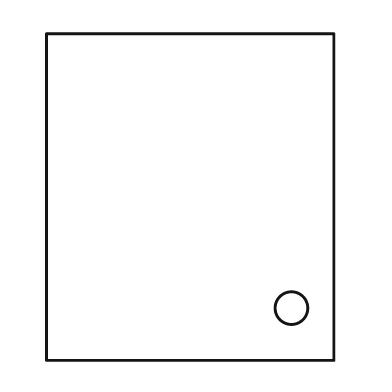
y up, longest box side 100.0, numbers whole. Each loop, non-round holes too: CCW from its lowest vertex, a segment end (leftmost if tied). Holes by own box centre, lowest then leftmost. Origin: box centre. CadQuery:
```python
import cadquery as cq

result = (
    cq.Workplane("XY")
    .moveTo(-44.0, -50.0)
    .lineTo(44.0, -50.0)
    .lineTo(44.0, 50.0)
    .lineTo(-44.0, 50.0)
    .close()
    .moveTo(31.0, -34.0)
    .circle(5.0)
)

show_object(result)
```